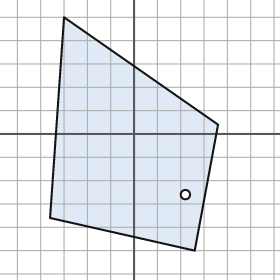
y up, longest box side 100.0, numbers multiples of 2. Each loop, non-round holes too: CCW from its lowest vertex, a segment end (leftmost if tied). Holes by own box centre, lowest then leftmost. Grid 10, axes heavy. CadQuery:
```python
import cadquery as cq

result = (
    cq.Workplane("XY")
    .moveTo(26.0, -50.0)
    .lineTo(36.0, 4.0)
    .lineTo(-30.0, 50.0)
    .lineTo(-36.0, -36.0)
    .close()
    .moveTo(22.0, -26.0)
    .circle(2.0)
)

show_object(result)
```